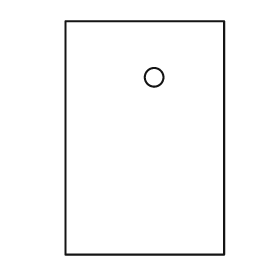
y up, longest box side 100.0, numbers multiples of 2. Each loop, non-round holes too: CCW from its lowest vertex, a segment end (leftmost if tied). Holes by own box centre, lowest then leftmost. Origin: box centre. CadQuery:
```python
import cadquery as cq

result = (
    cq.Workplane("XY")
    .moveTo(-34.0, -50.0)
    .lineTo(34.0, -50.0)
    .lineTo(34.0, 50.0)
    .lineTo(-34.0, 50.0)
    .close()
    .moveTo(4.0, 26.0)
    .circle(4.0)
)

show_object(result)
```